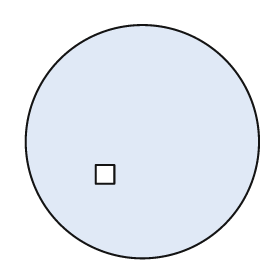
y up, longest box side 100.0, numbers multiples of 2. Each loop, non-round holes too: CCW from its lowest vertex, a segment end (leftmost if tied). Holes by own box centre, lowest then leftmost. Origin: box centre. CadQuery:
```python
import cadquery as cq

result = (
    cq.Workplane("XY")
    .moveTo(0.0, 0.0)
    .circle(50.0)
    .moveTo(-20.0, -18.0)
    .lineTo(-12.0, -18.0)
    .lineTo(-12.0, -10.0)
    .lineTo(-20.0, -10.0)
    .close()
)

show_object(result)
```